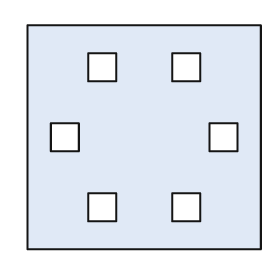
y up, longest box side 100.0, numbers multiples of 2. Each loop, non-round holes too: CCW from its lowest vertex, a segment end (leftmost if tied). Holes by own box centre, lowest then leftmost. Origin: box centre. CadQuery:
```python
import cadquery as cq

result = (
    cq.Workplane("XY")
    .moveTo(-50.0, -48.0)
    .lineTo(50.0, -48.0)
    .lineTo(50.0, 48.0)
    .lineTo(-50.0, 48.0)
    .close()
    .moveTo(-24.0, -36.0)
    .lineTo(-12.0, -36.0)
    .lineTo(-12.0, -24.0)
    .lineTo(-24.0, -24.0)
    .close()
    .moveTo(12.0, -36.0)
    .lineTo(24.0, -36.0)
    .lineTo(24.0, -24.0)
    .lineTo(12.0, -24.0)
    .close()
    .moveTo(-40.0, -6.0)
    .lineTo(-28.0, -6.0)
    .lineTo(-28.0, 6.0)
    .lineTo(-40.0, 6.0)
    .close()
    .moveTo(28.0, -6.0)
    .lineTo(40.0, -6.0)
    .lineTo(40.0, 6.0)
    .lineTo(28.0, 6.0)
    .close()
    .moveTo(-24.0, 24.0)
    .lineTo(-12.0, 24.0)
    .lineTo(-12.0, 36.0)
    .lineTo(-24.0, 36.0)
    .close()
    .moveTo(12.0, 24.0)
    .lineTo(24.0, 24.0)
    .lineTo(24.0, 36.0)
    .lineTo(12.0, 36.0)
    .close()
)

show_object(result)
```